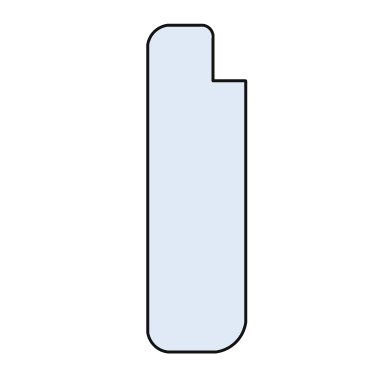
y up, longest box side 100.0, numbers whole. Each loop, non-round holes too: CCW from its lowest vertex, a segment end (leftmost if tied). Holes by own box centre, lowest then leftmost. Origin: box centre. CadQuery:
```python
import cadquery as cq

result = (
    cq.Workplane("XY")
    .moveTo(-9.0, -50.0)
    .lineTo(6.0, -50.0)
    .threePointArc((12.0, -47.0), (15.0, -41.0))
    .lineTo(15.0, 33.0)
    .lineTo(5.0, 33.0)
    .lineTo(5.0, 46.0)
    .threePointArc((4.0, 49.0), (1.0, 50.0))
    .lineTo(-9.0, 50.0)
    .threePointArc((-13.0, 48.0), (-15.0, 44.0))
    .lineTo(-15.0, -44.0)
    .threePointArc((-13.0, -48.0), (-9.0, -50.0))
    .close()
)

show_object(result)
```